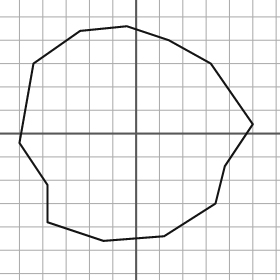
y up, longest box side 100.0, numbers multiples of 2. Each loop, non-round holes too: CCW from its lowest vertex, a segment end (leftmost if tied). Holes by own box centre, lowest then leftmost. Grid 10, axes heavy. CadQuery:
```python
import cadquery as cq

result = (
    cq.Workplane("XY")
    .moveTo(-14.0, -46.0)
    .lineTo(12.0, -44.0)
    .lineTo(34.0, -30.0)
    .lineTo(38.0, -14.0)
    .lineTo(50.0, 4.0)
    .lineTo(32.0, 30.0)
    .lineTo(14.0, 40.0)
    .lineTo(-4.0, 46.0)
    .lineTo(-24.0, 44.0)
    .lineTo(-44.0, 30.0)
    .lineTo(-50.0, -4.0)
    .lineTo(-38.0, -22.0)
    .lineTo(-38.0, -38.0)
    .close()
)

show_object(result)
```